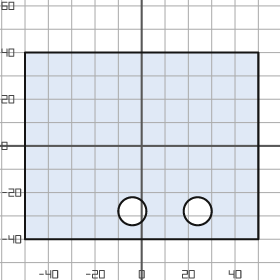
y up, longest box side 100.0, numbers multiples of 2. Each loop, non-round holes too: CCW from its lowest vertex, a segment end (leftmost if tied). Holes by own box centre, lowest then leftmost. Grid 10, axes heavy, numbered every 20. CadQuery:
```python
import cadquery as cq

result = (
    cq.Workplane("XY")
    .moveTo(-50.0, -40.0)
    .lineTo(50.0, -40.0)
    .lineTo(50.0, 40.0)
    .lineTo(-50.0, 40.0)
    .close()
    .moveTo(-4.0, -28.0)
    .circle(6.0)
    .moveTo(24.0, -28.0)
    .circle(6.0)
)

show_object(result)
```